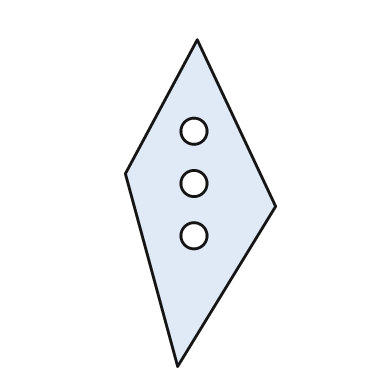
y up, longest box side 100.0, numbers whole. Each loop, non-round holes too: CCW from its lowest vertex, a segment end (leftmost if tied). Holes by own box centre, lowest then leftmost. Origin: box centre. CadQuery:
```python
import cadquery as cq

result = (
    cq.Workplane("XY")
    .moveTo(-7.0, -50.0)
    .lineTo(23.0, -1.0)
    .lineTo(-1.0, 50.0)
    .lineTo(-23.0, 9.0)
    .close()
    .moveTo(-2.0, -10.0)
    .circle(4.0)
    .moveTo(-2.0, 6.0)
    .circle(4.0)
    .moveTo(-2.0, 22.0)
    .circle(4.0)
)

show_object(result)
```